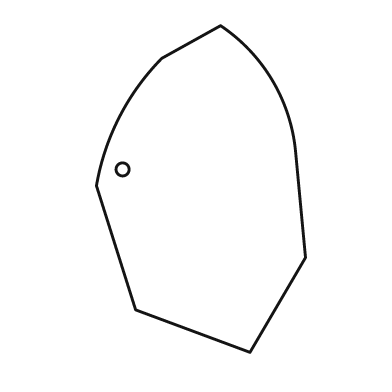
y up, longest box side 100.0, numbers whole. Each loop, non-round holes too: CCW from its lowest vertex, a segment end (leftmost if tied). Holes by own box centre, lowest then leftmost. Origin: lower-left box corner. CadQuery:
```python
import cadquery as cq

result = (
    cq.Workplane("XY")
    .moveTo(47.0, 0.0)
    .lineTo(64.0, 29.0)
    .lineTo(61.0, 61.0)
    .threePointArc((54.0, 83.0), (38.0, 100.0))
    .lineTo(20.0, 90.0)
    .threePointArc((7.0, 72.0), (0.0, 51.0))
    .lineTo(12.0, 13.0)
    .close()
    .moveTo(8.0, 56.0)
    .circle(2.0)
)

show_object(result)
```